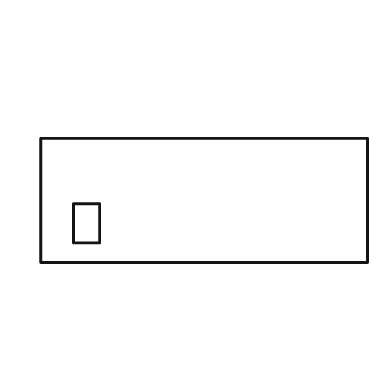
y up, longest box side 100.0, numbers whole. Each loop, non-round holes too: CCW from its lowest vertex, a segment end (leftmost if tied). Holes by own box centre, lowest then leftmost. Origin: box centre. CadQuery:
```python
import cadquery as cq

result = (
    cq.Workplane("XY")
    .moveTo(-50.0, -19.0)
    .lineTo(50.0, -19.0)
    .lineTo(50.0, 19.0)
    .lineTo(-50.0, 19.0)
    .close()
    .moveTo(-40.0, -13.0)
    .lineTo(-32.0, -13.0)
    .lineTo(-32.0, -1.0)
    .lineTo(-40.0, -1.0)
    .close()
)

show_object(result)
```